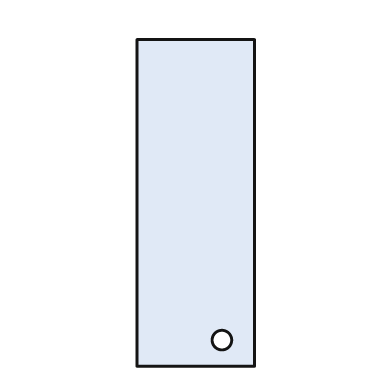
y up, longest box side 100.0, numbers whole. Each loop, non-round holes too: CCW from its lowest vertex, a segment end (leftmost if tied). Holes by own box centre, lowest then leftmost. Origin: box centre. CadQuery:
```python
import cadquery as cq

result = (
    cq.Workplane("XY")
    .moveTo(-18.0, -50.0)
    .lineTo(18.0, -50.0)
    .lineTo(18.0, 50.0)
    .lineTo(-18.0, 50.0)
    .close()
    .moveTo(8.0, -42.0)
    .circle(3.0)
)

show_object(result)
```